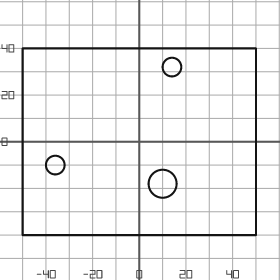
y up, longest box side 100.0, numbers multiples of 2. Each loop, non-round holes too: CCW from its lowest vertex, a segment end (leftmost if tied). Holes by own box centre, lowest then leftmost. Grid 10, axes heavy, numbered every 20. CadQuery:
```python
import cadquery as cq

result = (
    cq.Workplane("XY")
    .moveTo(-50.0, -40.0)
    .lineTo(50.0, -40.0)
    .lineTo(50.0, 40.0)
    .lineTo(-50.0, 40.0)
    .close()
    .moveTo(10.0, -18.0)
    .circle(6.0)
    .moveTo(-36.0, -10.0)
    .circle(4.0)
    .moveTo(14.0, 32.0)
    .circle(4.0)
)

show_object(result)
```